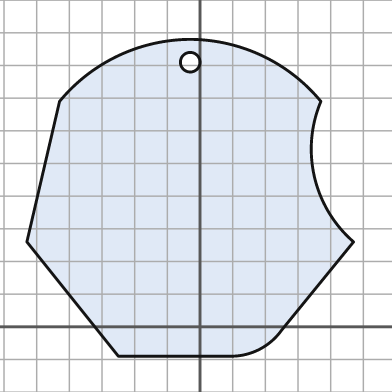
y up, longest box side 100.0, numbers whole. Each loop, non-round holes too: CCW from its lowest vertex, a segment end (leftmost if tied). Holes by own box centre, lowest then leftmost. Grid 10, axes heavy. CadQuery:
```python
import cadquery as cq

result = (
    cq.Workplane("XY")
    .moveTo(-25.0, -9.0)
    .lineTo(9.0, -9.0)
    .threePointArc((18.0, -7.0), (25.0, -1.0))
    .lineTo(47.0, 26.0)
    .threePointArc((35.0, 46.0), (37.0, 69.0))
    .threePointArc((19.0, 83.0), (-3.0, 88.0))
    .threePointArc((-25.0, 83.0), (-43.0, 69.0))
    .lineTo(-53.0, 26.0)
    .close()
    .moveTo(-3.0, 81.0)
    .circle(3.0)
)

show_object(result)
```